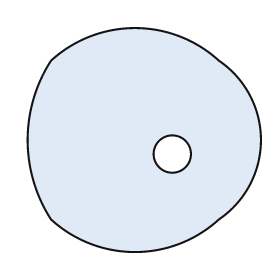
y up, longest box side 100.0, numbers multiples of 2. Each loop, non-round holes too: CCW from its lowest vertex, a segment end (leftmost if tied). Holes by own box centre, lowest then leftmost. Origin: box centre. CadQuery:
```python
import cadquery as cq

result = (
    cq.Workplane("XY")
    .moveTo(-40.0, -34.0)
    .threePointArc((-4.0, -48.0), (32.0, -34.0))
    .threePointArc((50.0, 0.0), (32.0, 34.0))
    .threePointArc((-4.0, 48.0), (-40.0, 34.0))
    .threePointArc((-50.0, 0.0), (-40.0, -34.0))
    .close()
    .moveTo(12.0, -6.0)
    .circle(8.0)
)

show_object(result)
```